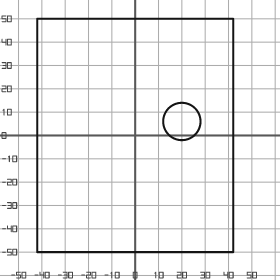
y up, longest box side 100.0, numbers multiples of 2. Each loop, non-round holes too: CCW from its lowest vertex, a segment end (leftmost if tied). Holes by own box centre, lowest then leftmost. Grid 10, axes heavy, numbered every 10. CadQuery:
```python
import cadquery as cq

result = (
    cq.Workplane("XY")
    .moveTo(-42.0, -50.0)
    .lineTo(42.0, -50.0)
    .lineTo(42.0, 50.0)
    .lineTo(-42.0, 50.0)
    .close()
    .moveTo(20.0, 6.0)
    .circle(8.0)
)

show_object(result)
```